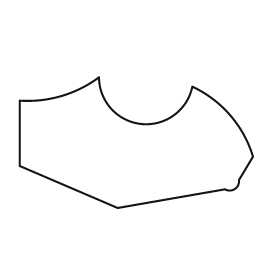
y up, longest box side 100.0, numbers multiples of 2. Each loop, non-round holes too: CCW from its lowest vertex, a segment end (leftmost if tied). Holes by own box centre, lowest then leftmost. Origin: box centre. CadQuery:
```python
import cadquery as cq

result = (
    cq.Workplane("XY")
    .moveTo(-8.0, -28.0)
    .lineTo(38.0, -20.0)
    .threePointArc((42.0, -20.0), (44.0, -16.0))
    .lineTo(50.0, -6.0)
    .threePointArc((40.0, 12.0), (24.0, 24.0))
    .threePointArc((2.0, 8.0), (-16.0, 28.0))
    .threePointArc((-32.0, 20.0), (-50.0, 18.0))
    .lineTo(-50.0, -10.0)
    .close()
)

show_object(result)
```